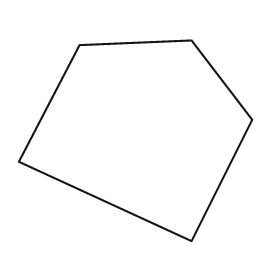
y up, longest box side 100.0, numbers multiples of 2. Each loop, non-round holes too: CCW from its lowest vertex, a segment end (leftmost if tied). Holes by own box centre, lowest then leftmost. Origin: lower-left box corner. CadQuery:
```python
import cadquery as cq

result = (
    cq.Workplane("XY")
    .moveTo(74.0, 0.0)
    .lineTo(100.0, 52.0)
    .lineTo(74.0, 86.0)
    .lineTo(26.0, 84.0)
    .lineTo(0.0, 34.0)
    .close()
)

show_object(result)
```